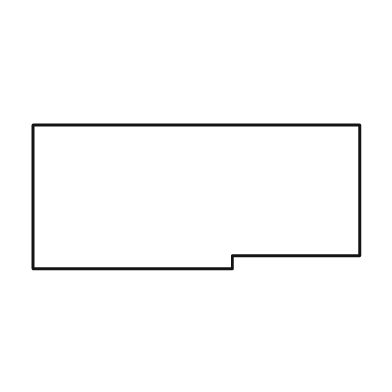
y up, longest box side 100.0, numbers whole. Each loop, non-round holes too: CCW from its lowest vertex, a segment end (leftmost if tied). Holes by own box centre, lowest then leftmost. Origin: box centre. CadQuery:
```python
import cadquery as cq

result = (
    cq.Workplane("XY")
    .moveTo(-50.0, -22.0)
    .lineTo(11.0, -22.0)
    .lineTo(11.0, -18.0)
    .lineTo(50.0, -18.0)
    .lineTo(50.0, 22.0)
    .lineTo(-50.0, 22.0)
    .close()
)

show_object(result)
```